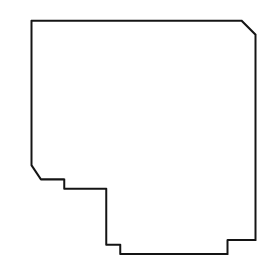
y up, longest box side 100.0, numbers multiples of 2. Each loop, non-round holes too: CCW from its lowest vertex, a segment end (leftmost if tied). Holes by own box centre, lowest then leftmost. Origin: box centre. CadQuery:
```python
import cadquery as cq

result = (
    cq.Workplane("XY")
    .moveTo(-10.0, -50.0)
    .lineTo(36.0, -50.0)
    .lineTo(36.0, -44.0)
    .lineTo(48.0, -44.0)
    .lineTo(48.0, 44.0)
    .lineTo(42.0, 50.0)
    .lineTo(-48.0, 50.0)
    .lineTo(-48.0, -12.0)
    .lineTo(-44.0, -18.0)
    .lineTo(-34.0, -18.0)
    .lineTo(-34.0, -22.0)
    .lineTo(-16.0, -22.0)
    .lineTo(-16.0, -46.0)
    .lineTo(-10.0, -46.0)
    .close()
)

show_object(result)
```